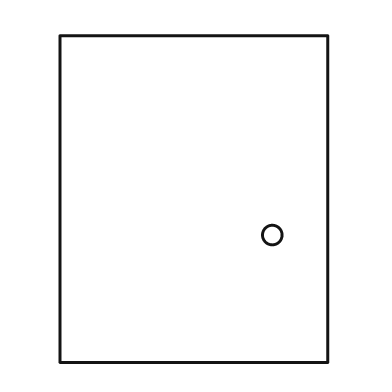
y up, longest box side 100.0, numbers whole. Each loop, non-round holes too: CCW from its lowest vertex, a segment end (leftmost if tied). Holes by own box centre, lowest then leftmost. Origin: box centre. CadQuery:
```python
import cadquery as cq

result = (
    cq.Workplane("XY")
    .moveTo(-41.0, -50.0)
    .lineTo(41.0, -50.0)
    .lineTo(41.0, 50.0)
    .lineTo(-41.0, 50.0)
    .close()
    .moveTo(24.0, -11.0)
    .circle(3.0)
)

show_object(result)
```